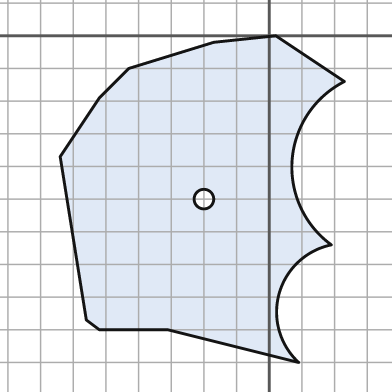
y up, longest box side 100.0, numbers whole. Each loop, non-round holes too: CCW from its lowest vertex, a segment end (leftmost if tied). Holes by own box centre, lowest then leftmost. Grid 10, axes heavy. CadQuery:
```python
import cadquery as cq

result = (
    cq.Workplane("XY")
    .moveTo(9.0, -100.0)
    .threePointArc((3.0, -79.0), (19.0, -64.0))
    .threePointArc((7.0, -38.0), (23.0, -14.0))
    .lineTo(2.0, 0.0)
    .lineTo(-17.0, -2.0)
    .lineTo(-43.0, -10.0)
    .lineTo(-52.0, -19.0)
    .lineTo(-64.0, -37.0)
    .lineTo(-56.0, -87.0)
    .lineTo(-52.0, -90.0)
    .lineTo(-31.0, -90.0)
    .close()
    .moveTo(-20.0, -50.0)
    .circle(3.0)
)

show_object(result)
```